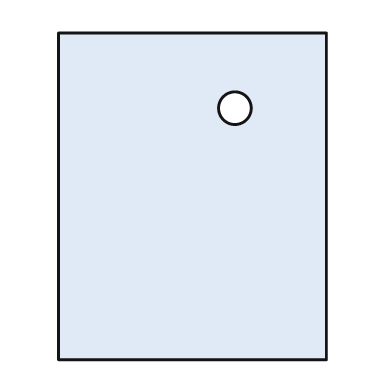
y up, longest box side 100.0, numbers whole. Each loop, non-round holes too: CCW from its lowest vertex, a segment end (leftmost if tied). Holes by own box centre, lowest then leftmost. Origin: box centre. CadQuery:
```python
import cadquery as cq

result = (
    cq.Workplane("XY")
    .moveTo(-41.0, -50.0)
    .lineTo(41.0, -50.0)
    .lineTo(41.0, 50.0)
    .lineTo(-41.0, 50.0)
    .close()
    .moveTo(13.0, 27.0)
    .circle(5.0)
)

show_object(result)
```